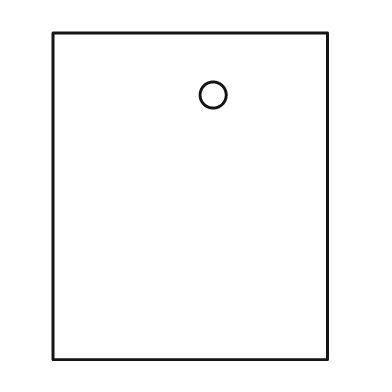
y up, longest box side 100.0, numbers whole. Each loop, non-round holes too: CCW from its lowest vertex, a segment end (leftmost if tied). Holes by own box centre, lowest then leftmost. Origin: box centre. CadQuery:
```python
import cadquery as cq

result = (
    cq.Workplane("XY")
    .moveTo(-42.0, -50.0)
    .lineTo(42.0, -50.0)
    .lineTo(42.0, 50.0)
    .lineTo(-42.0, 50.0)
    .close()
    .moveTo(7.0, 31.0)
    .circle(4.0)
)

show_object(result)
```